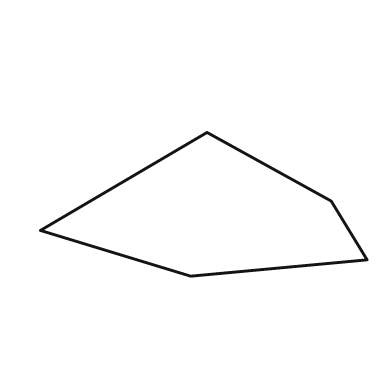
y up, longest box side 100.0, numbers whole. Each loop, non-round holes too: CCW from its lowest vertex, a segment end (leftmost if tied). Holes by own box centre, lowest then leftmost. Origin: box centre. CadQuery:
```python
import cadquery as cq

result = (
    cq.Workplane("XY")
    .moveTo(-4.0, -22.0)
    .lineTo(50.0, -17.0)
    .lineTo(39.0, 1.0)
    .lineTo(1.0, 22.0)
    .lineTo(-50.0, -8.0)
    .close()
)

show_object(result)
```